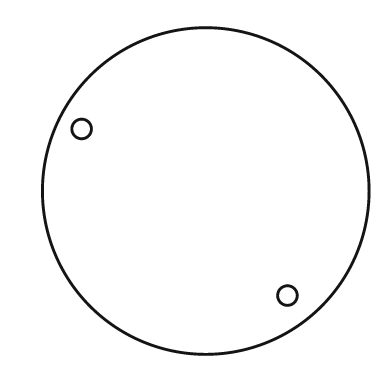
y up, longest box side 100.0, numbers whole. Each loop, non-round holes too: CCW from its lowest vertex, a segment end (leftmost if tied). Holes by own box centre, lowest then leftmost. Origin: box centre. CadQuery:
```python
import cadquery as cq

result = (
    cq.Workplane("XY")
    .moveTo(0.0, 0.0)
    .circle(50.0)
    .moveTo(25.0, -32.0)
    .circle(3.0)
    .moveTo(-38.0, 19.0)
    .circle(3.0)
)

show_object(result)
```